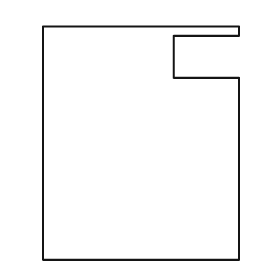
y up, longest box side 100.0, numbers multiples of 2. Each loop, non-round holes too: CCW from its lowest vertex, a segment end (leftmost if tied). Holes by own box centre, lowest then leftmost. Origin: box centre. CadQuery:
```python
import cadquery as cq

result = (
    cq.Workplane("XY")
    .moveTo(-42.0, -50.0)
    .lineTo(42.0, -50.0)
    .lineTo(42.0, 28.0)
    .lineTo(14.0, 28.0)
    .lineTo(14.0, 46.0)
    .lineTo(42.0, 46.0)
    .lineTo(42.0, 50.0)
    .lineTo(-42.0, 50.0)
    .close()
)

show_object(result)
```